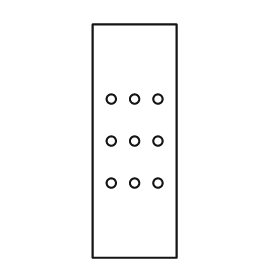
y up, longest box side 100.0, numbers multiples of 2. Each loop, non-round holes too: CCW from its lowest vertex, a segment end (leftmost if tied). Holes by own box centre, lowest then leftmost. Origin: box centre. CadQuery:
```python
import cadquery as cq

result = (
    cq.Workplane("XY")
    .moveTo(-18.0, -50.0)
    .lineTo(18.0, -50.0)
    .lineTo(18.0, 50.0)
    .lineTo(-18.0, 50.0)
    .close()
    .moveTo(-10.0, -18.0)
    .circle(2.0)
    .moveTo(0.0, -18.0)
    .circle(2.0)
    .moveTo(10.0, -18.0)
    .circle(2.0)
    .moveTo(-10.0, 0.0)
    .circle(2.0)
    .moveTo(0.0, 0.0)
    .circle(2.0)
    .moveTo(10.0, 0.0)
    .circle(2.0)
    .moveTo(-10.0, 18.0)
    .circle(2.0)
    .moveTo(0.0, 18.0)
    .circle(2.0)
    .moveTo(10.0, 18.0)
    .circle(2.0)
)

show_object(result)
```